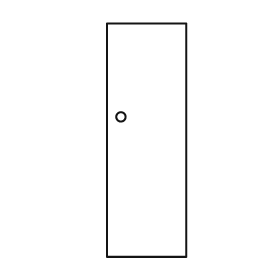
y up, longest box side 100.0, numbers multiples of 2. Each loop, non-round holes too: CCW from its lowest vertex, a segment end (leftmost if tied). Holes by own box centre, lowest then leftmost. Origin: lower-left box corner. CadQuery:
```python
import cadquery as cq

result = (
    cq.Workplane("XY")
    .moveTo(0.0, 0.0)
    .lineTo(34.0, 0.0)
    .lineTo(34.0, 100.0)
    .lineTo(0.0, 100.0)
    .close()
    .moveTo(6.0, 60.0)
    .circle(2.0)
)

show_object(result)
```